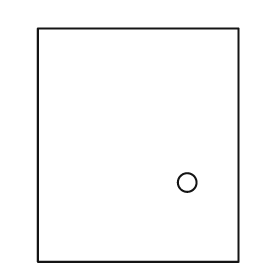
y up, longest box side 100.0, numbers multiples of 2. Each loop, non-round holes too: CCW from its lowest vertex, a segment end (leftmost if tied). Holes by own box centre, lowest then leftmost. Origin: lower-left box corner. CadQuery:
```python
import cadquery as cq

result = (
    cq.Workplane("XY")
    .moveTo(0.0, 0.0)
    .lineTo(86.0, 0.0)
    .lineTo(86.0, 100.0)
    .lineTo(0.0, 100.0)
    .close()
    .moveTo(64.0, 34.0)
    .circle(4.0)
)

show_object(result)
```